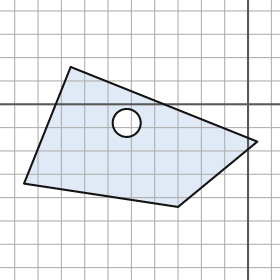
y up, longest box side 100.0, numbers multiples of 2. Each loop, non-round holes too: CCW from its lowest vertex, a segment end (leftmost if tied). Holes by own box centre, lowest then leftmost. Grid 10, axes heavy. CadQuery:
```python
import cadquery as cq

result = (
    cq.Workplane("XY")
    .moveTo(-30.0, -44.0)
    .lineTo(4.0, -16.0)
    .lineTo(-76.0, 16.0)
    .lineTo(-96.0, -34.0)
    .close()
    .moveTo(-52.0, -8.0)
    .circle(6.0)
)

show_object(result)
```